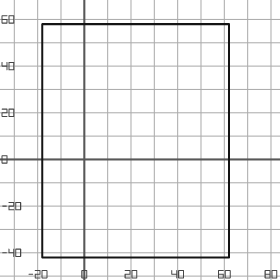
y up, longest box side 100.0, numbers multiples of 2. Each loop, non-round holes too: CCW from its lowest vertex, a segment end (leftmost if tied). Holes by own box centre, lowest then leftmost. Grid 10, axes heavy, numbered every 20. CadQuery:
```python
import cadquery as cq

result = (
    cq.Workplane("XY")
    .moveTo(-18.0, -42.0)
    .lineTo(62.0, -42.0)
    .lineTo(62.0, 58.0)
    .lineTo(-18.0, 58.0)
    .close()
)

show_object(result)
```